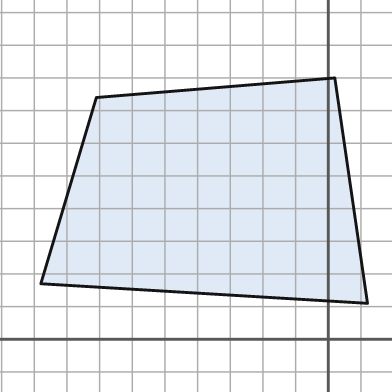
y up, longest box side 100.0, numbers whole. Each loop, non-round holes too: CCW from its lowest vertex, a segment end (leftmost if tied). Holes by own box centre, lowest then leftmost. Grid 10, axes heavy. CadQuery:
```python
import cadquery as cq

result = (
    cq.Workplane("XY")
    .moveTo(12.0, 11.0)
    .lineTo(2.0, 80.0)
    .lineTo(-71.0, 74.0)
    .lineTo(-88.0, 17.0)
    .close()
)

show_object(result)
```